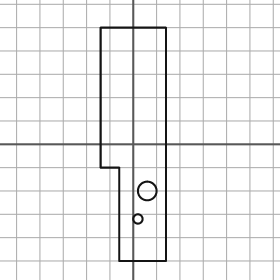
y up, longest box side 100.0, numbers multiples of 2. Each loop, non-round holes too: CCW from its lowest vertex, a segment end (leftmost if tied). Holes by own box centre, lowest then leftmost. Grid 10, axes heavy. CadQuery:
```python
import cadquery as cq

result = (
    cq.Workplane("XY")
    .moveTo(-6.0, -50.0)
    .lineTo(14.0, -50.0)
    .lineTo(14.0, 50.0)
    .lineTo(-14.0, 50.0)
    .lineTo(-14.0, -10.0)
    .lineTo(-6.0, -10.0)
    .close()
    .moveTo(2.0, -32.0)
    .circle(2.0)
    .moveTo(6.0, -20.0)
    .circle(4.0)
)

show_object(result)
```